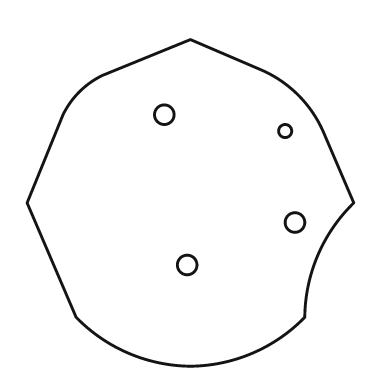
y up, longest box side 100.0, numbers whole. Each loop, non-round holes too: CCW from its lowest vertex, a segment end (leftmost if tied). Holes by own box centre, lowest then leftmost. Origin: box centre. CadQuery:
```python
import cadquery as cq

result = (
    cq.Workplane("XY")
    .moveTo(0.0, -50.0)
    .threePointArc((19.0, -46.0), (35.0, -35.0))
    .threePointArc((39.0, -16.0), (50.0, 0.0))
    .lineTo(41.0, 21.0)
    .threePointArc((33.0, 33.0), (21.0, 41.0))
    .lineTo(0.0, 50.0)
    .lineTo(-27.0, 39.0)
    .threePointArc((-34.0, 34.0), (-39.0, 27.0))
    .lineTo(-50.0, 0.0)
    .lineTo(-35.0, -35.0)
    .threePointArc((-19.0, -46.0), (0.0, -50.0))
    .close()
    .moveTo(-1.0, -19.0)
    .circle(3.0)
    .moveTo(32.0, -6.0)
    .circle(3.0)
    .moveTo(29.0, 22.0)
    .circle(2.0)
    .moveTo(-8.0, 27.0)
    .circle(3.0)
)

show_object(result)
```